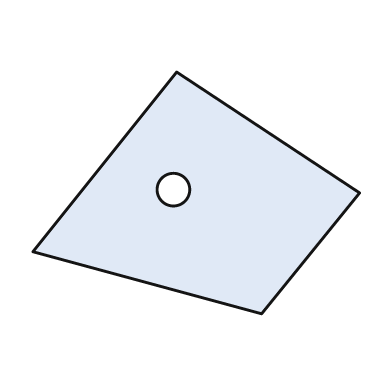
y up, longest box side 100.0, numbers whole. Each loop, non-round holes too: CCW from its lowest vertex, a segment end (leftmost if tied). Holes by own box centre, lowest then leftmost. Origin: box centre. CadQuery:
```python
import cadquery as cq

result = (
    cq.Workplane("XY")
    .moveTo(20.0, -37.0)
    .lineTo(50.0, 0.0)
    .lineTo(-6.0, 37.0)
    .lineTo(-50.0, -18.0)
    .close()
    .moveTo(-7.0, 1.0)
    .circle(5.0)
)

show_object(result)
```